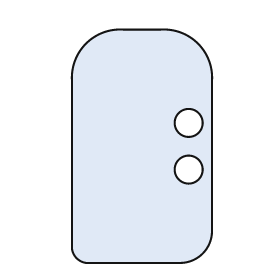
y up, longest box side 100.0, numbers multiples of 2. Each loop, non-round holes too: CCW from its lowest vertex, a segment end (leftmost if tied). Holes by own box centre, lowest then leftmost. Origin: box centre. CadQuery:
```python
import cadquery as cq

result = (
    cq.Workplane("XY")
    .moveTo(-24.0, -50.0)
    .lineTo(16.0, -50.0)
    .threePointArc((26.0, -46.0), (30.0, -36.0))
    .lineTo(30.0, 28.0)
    .threePointArc((24.0, 44.0), (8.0, 50.0))
    .lineTo(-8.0, 50.0)
    .threePointArc((-24.0, 44.0), (-30.0, 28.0))
    .lineTo(-30.0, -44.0)
    .threePointArc((-28.0, -48.0), (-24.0, -50.0))
    .close()
    .moveTo(20.0, -10.0)
    .circle(6.0)
    .moveTo(20.0, 10.0)
    .circle(6.0)
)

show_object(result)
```